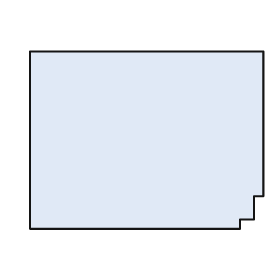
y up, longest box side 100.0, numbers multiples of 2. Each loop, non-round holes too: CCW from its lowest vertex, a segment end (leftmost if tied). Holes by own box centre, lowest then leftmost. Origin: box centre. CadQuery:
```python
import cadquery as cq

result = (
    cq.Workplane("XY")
    .moveTo(-50.0, -38.0)
    .lineTo(40.0, -38.0)
    .lineTo(40.0, -34.0)
    .lineTo(46.0, -34.0)
    .lineTo(46.0, -24.0)
    .lineTo(50.0, -24.0)
    .lineTo(50.0, 38.0)
    .lineTo(-50.0, 38.0)
    .close()
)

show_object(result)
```